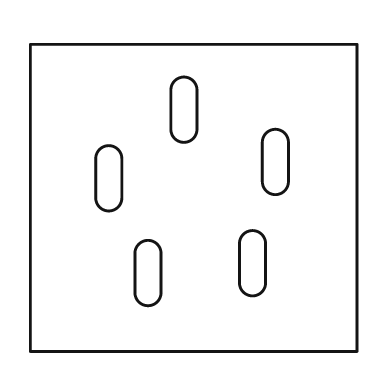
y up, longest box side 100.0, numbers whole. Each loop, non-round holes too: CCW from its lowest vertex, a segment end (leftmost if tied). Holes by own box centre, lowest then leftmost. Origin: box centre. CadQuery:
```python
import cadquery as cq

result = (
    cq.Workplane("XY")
    .moveTo(-50.0, -47.0)
    .lineTo(50.0, -47.0)
    .lineTo(50.0, 47.0)
    .lineTo(-50.0, 47.0)
    .close()
    .moveTo(-18.0, -29.0)
    .threePointArc((-14.0, -33.0), (-10.0, -29.0))
    .lineTo(-10.0, -17.0)
    .threePointArc((-14.0, -13.0), (-18.0, -17.0))
    .close()
    .moveTo(14.0, -26.0)
    .threePointArc((18.0, -30.0), (22.0, -26.0))
    .lineTo(22.0, -14.0)
    .threePointArc((18.0, -10.0), (14.0, -14.0))
    .close()
    .moveTo(-30.0, 0.0)
    .threePointArc((-26.0, -4.0), (-22.0, 0.0))
    .lineTo(-22.0, 12.0)
    .threePointArc((-26.0, 16.0), (-30.0, 12.0))
    .close()
    .moveTo(21.0, 5.0)
    .threePointArc((25.0, 1.0), (29.0, 5.0))
    .lineTo(29.0, 17.0)
    .threePointArc((25.0, 21.0), (21.0, 17.0))
    .close()
    .moveTo(-7.0, 21.0)
    .threePointArc((-3.0, 17.0), (1.0, 21.0))
    .lineTo(1.0, 33.0)
    .threePointArc((-3.0, 37.0), (-7.0, 33.0))
    .close()
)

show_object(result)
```